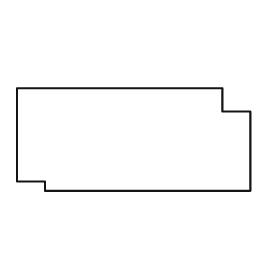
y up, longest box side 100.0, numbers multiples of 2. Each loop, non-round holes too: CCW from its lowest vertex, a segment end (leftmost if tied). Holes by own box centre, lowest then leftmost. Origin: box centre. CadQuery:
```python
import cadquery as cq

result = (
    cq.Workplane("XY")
    .moveTo(-38.0, -22.0)
    .lineTo(50.0, -22.0)
    .lineTo(50.0, 12.0)
    .lineTo(38.0, 12.0)
    .lineTo(38.0, 22.0)
    .lineTo(-50.0, 22.0)
    .lineTo(-50.0, -18.0)
    .lineTo(-38.0, -18.0)
    .close()
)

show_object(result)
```